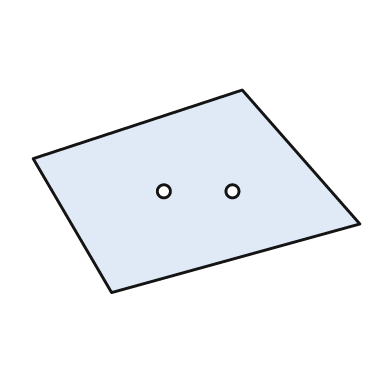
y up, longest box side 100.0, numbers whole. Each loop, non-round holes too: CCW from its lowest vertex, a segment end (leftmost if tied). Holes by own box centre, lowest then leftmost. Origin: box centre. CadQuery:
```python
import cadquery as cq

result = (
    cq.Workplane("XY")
    .moveTo(-26.0, -31.0)
    .lineTo(50.0, -10.0)
    .lineTo(14.0, 31.0)
    .lineTo(-50.0, 10.0)
    .close()
    .moveTo(-10.0, 0.0)
    .circle(2.0)
    .moveTo(11.0, 0.0)
    .circle(2.0)
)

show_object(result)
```